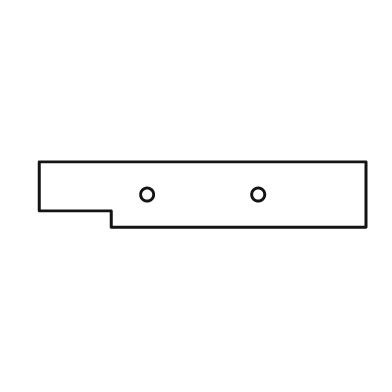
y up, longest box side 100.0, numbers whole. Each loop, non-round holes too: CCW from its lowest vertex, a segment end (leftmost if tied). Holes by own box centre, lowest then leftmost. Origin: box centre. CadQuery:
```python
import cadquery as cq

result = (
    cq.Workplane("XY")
    .moveTo(-28.0, -10.0)
    .lineTo(50.0, -10.0)
    .lineTo(50.0, 10.0)
    .lineTo(-50.0, 10.0)
    .lineTo(-50.0, -5.0)
    .lineTo(-28.0, -5.0)
    .close()
    .moveTo(-17.0, 0.0)
    .circle(2.0)
    .moveTo(17.0, 0.0)
    .circle(2.0)
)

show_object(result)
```